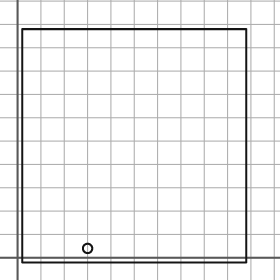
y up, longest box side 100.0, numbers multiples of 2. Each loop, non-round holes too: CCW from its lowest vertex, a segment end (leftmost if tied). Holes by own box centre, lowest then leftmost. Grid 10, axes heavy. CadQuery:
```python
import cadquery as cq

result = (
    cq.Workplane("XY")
    .moveTo(2.0, -2.0)
    .lineTo(98.0, -2.0)
    .lineTo(98.0, 98.0)
    .lineTo(2.0, 98.0)
    .close()
    .moveTo(30.0, 4.0)
    .circle(2.0)
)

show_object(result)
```